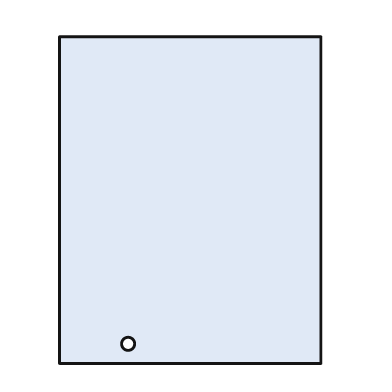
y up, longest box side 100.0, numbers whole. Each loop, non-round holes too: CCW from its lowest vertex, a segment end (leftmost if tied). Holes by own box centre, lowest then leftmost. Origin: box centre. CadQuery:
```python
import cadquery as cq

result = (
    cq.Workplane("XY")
    .moveTo(-40.0, -50.0)
    .lineTo(40.0, -50.0)
    .lineTo(40.0, 50.0)
    .lineTo(-40.0, 50.0)
    .close()
    .moveTo(-19.0, -44.0)
    .circle(2.0)
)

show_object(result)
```